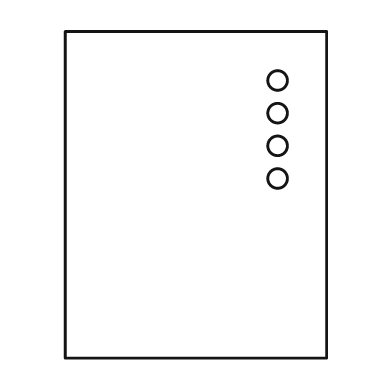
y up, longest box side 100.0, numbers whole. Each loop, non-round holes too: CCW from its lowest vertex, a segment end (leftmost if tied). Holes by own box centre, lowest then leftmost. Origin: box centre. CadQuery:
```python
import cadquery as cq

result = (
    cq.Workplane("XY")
    .moveTo(-40.0, -50.0)
    .lineTo(40.0, -50.0)
    .lineTo(40.0, 50.0)
    .lineTo(-40.0, 50.0)
    .close()
    .moveTo(25.0, 5.0)
    .circle(3.0)
    .moveTo(25.0, 15.0)
    .circle(3.0)
    .moveTo(25.0, 25.0)
    .circle(3.0)
    .moveTo(25.0, 35.0)
    .circle(3.0)
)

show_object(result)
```